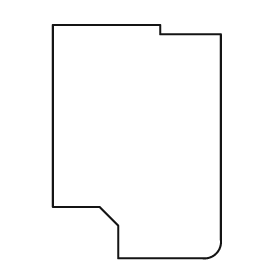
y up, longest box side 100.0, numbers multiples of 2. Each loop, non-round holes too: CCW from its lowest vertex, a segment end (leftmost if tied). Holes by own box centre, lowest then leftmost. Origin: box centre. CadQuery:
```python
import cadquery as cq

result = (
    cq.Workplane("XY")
    .moveTo(-8.0, -50.0)
    .lineTo(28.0, -50.0)
    .threePointArc((34.0, -48.0), (36.0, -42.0))
    .lineTo(36.0, 46.0)
    .lineTo(10.0, 46.0)
    .lineTo(10.0, 50.0)
    .lineTo(-36.0, 50.0)
    .lineTo(-36.0, -28.0)
    .lineTo(-16.0, -28.0)
    .lineTo(-8.0, -36.0)
    .close()
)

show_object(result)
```